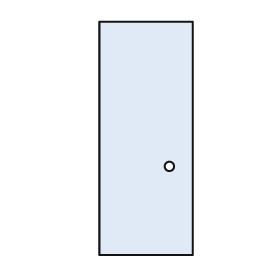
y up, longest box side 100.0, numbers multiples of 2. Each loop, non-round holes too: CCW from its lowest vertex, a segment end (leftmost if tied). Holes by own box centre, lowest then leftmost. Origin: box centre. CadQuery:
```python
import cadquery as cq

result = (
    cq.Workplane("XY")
    .moveTo(-20.0, -50.0)
    .lineTo(20.0, -50.0)
    .lineTo(20.0, 50.0)
    .lineTo(-20.0, 50.0)
    .close()
    .moveTo(10.0, -12.0)
    .circle(2.0)
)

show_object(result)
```